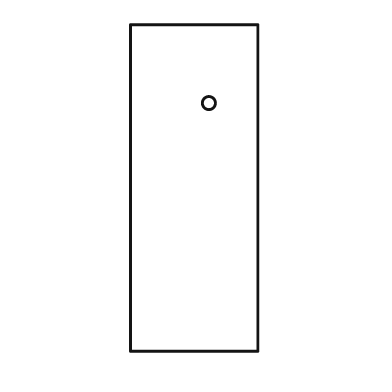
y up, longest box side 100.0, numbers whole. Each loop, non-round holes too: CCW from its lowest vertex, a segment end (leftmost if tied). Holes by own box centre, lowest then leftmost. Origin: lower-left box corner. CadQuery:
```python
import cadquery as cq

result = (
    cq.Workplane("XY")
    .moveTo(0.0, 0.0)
    .lineTo(39.0, 0.0)
    .lineTo(39.0, 100.0)
    .lineTo(0.0, 100.0)
    .close()
    .moveTo(24.0, 76.0)
    .circle(2.0)
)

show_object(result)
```